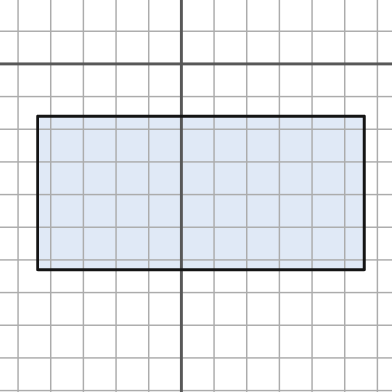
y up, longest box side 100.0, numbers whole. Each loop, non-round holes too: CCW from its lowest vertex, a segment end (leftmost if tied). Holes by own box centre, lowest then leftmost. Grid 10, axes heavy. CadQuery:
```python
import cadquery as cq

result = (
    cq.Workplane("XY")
    .moveTo(-44.0, -63.0)
    .lineTo(56.0, -63.0)
    .lineTo(56.0, -16.0)
    .lineTo(-44.0, -16.0)
    .close()
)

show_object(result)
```